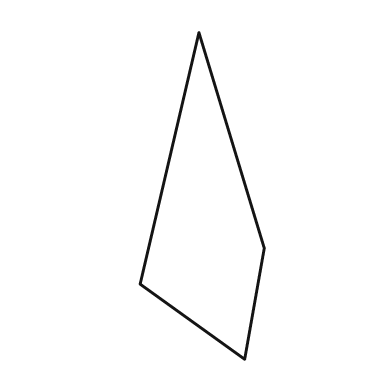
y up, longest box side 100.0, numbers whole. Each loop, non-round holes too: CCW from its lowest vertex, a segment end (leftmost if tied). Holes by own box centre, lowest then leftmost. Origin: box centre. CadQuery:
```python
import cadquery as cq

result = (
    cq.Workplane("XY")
    .moveTo(13.0, -50.0)
    .lineTo(19.0, -16.0)
    .lineTo(-1.0, 50.0)
    .lineTo(-19.0, -27.0)
    .close()
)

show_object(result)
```